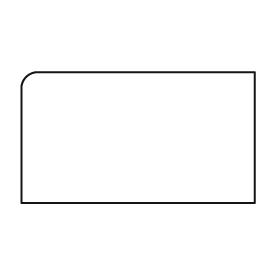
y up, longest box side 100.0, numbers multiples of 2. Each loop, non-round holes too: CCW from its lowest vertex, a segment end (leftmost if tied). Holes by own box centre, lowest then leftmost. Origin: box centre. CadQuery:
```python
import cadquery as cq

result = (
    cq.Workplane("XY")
    .moveTo(-50.0, -28.0)
    .lineTo(50.0, -28.0)
    .lineTo(50.0, 28.0)
    .lineTo(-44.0, 28.0)
    .threePointArc((-48.0, 26.0), (-50.0, 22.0))
    .close()
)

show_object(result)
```